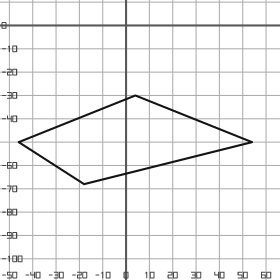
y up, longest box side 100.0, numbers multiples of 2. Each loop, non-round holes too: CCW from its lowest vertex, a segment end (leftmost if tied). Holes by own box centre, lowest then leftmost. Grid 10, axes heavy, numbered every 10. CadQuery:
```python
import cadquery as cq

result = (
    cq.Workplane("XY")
    .moveTo(-18.0, -68.0)
    .lineTo(54.0, -50.0)
    .lineTo(4.0, -30.0)
    .lineTo(-46.0, -50.0)
    .close()
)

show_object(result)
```